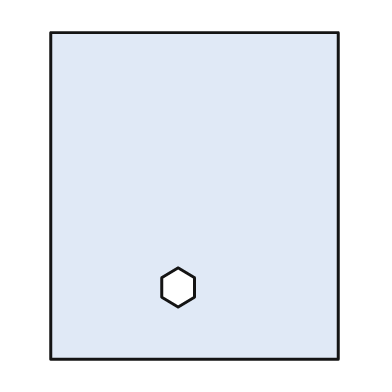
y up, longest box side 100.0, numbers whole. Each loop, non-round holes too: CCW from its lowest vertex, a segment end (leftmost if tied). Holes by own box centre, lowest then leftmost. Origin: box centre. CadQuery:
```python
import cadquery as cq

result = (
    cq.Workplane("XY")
    .moveTo(-44.0, -50.0)
    .lineTo(44.0, -50.0)
    .lineTo(44.0, 50.0)
    .lineTo(-44.0, 50.0)
    .close()
    .moveTo(-5.0, -34.0)
    .lineTo(0.0, -31.0)
    .lineTo(0.0, -25.0)
    .lineTo(-5.0, -22.0)
    .lineTo(-10.0, -25.0)
    .lineTo(-10.0, -31.0)
    .close()
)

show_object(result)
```